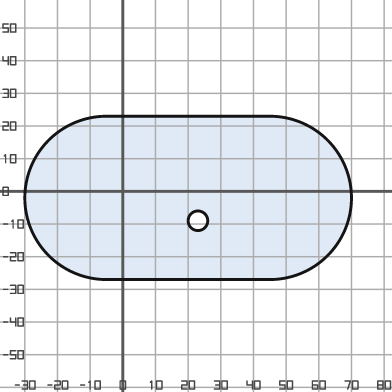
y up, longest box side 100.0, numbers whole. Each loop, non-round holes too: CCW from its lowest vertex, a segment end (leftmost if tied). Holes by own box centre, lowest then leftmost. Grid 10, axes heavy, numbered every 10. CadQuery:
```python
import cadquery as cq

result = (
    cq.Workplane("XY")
    .moveTo(-5.0, -27.0)
    .lineTo(45.0, -27.0)
    .threePointArc((70.0, -2.0), (45.0, 23.0))
    .lineTo(-5.0, 23.0)
    .threePointArc((-30.0, -2.0), (-5.0, -27.0))
    .close()
    .moveTo(23.0, -9.0)
    .circle(3.0)
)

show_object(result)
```